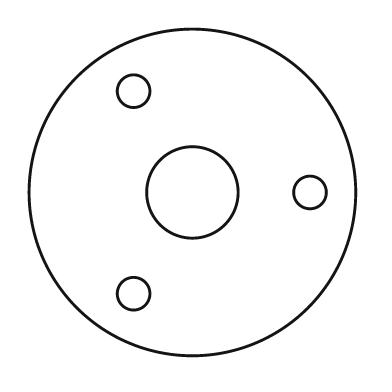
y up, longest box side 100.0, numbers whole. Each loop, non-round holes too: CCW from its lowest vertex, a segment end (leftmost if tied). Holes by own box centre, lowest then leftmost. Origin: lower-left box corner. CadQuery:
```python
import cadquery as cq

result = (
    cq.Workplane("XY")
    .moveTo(50.0, 50.0)
    .circle(50.0)
    .moveTo(32.0, 19.0)
    .circle(5.0)
    .moveTo(50.0, 50.0)
    .circle(14.0)
    .moveTo(86.0, 50.0)
    .circle(5.0)
    .moveTo(32.0, 81.0)
    .circle(5.0)
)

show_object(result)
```